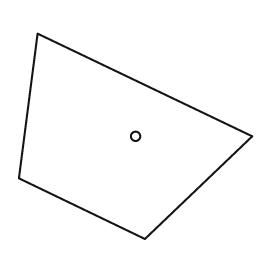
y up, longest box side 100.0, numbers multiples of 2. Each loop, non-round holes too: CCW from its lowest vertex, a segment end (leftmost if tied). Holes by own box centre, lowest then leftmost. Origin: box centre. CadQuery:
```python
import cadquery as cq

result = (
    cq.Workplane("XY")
    .moveTo(4.0, -44.0)
    .lineTo(50.0, 0.0)
    .lineTo(-42.0, 44.0)
    .lineTo(-50.0, -18.0)
    .close()
    .moveTo(0.0, 0.0)
    .circle(2.0)
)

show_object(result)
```